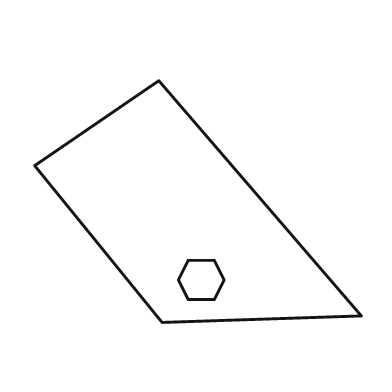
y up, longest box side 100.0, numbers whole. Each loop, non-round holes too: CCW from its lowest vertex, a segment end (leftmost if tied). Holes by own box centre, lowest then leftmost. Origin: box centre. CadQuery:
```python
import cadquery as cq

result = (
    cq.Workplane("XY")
    .moveTo(-11.0, -37.0)
    .lineTo(50.0, -35.0)
    .lineTo(-12.0, 37.0)
    .lineTo(-50.0, 11.0)
    .close()
    .moveTo(-3.0, -30.0)
    .lineTo(5.0, -30.0)
    .lineTo(8.0, -24.0)
    .lineTo(5.0, -18.0)
    .lineTo(-3.0, -18.0)
    .lineTo(-6.0, -24.0)
    .close()
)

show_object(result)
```